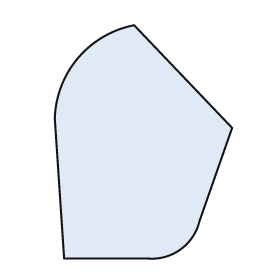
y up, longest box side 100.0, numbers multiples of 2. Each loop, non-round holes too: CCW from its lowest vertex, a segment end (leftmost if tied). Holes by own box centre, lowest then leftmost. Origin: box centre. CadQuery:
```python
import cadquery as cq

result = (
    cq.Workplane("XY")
    .moveTo(-34.0, -50.0)
    .lineTo(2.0, -50.0)
    .threePointArc((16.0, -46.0), (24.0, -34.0))
    .lineTo(38.0, 6.0)
    .lineTo(-4.0, 50.0)
    .threePointArc((-28.0, 36.0), (-38.0, 10.0))
    .close()
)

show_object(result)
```